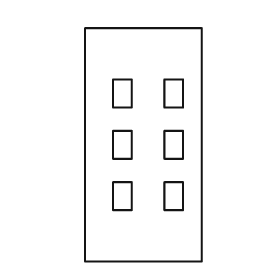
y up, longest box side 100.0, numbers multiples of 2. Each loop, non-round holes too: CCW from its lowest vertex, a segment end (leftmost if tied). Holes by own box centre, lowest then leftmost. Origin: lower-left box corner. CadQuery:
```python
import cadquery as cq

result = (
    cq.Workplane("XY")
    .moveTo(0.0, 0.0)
    .lineTo(50.0, 0.0)
    .lineTo(50.0, 100.0)
    .lineTo(0.0, 100.0)
    .close()
    .moveTo(12.0, 22.0)
    .lineTo(20.0, 22.0)
    .lineTo(20.0, 34.0)
    .lineTo(12.0, 34.0)
    .close()
    .moveTo(34.0, 22.0)
    .lineTo(42.0, 22.0)
    .lineTo(42.0, 34.0)
    .lineTo(34.0, 34.0)
    .close()
    .moveTo(12.0, 44.0)
    .lineTo(20.0, 44.0)
    .lineTo(20.0, 56.0)
    .lineTo(12.0, 56.0)
    .close()
    .moveTo(34.0, 44.0)
    .lineTo(42.0, 44.0)
    .lineTo(42.0, 56.0)
    .lineTo(34.0, 56.0)
    .close()
    .moveTo(12.0, 66.0)
    .lineTo(20.0, 66.0)
    .lineTo(20.0, 78.0)
    .lineTo(12.0, 78.0)
    .close()
    .moveTo(34.0, 66.0)
    .lineTo(42.0, 66.0)
    .lineTo(42.0, 78.0)
    .lineTo(34.0, 78.0)
    .close()
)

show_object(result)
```